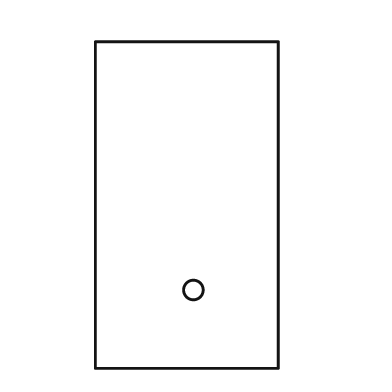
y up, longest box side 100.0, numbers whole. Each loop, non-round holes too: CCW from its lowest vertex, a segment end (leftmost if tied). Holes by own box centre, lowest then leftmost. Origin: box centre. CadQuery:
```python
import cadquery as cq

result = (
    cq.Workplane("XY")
    .moveTo(-28.0, -50.0)
    .lineTo(28.0, -50.0)
    .lineTo(28.0, 50.0)
    .lineTo(-28.0, 50.0)
    .close()
    .moveTo(2.0, -26.0)
    .circle(3.0)
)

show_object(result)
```